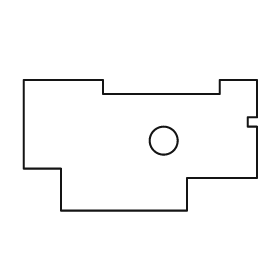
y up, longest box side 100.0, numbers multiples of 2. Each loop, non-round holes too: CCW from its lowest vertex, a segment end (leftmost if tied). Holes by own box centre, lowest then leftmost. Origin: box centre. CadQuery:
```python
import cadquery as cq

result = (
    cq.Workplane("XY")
    .moveTo(-34.0, -28.0)
    .lineTo(20.0, -28.0)
    .lineTo(20.0, -14.0)
    .lineTo(50.0, -14.0)
    .lineTo(50.0, 8.0)
    .lineTo(46.0, 8.0)
    .lineTo(46.0, 12.0)
    .lineTo(50.0, 12.0)
    .lineTo(50.0, 28.0)
    .lineTo(34.0, 28.0)
    .lineTo(34.0, 22.0)
    .lineTo(-16.0, 22.0)
    .lineTo(-16.0, 28.0)
    .lineTo(-50.0, 28.0)
    .lineTo(-50.0, -10.0)
    .lineTo(-34.0, -10.0)
    .close()
    .moveTo(10.0, 2.0)
    .circle(6.0)
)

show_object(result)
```